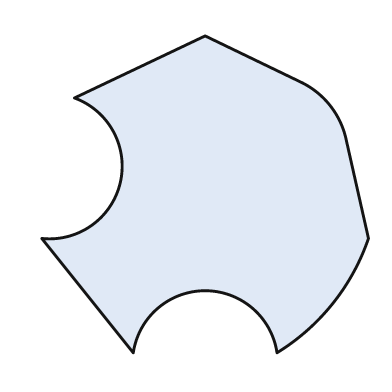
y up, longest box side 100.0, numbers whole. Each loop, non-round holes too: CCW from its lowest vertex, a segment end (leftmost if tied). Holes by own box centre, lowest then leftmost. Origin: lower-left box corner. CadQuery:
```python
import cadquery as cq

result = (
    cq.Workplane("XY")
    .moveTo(28.0, 0.0)
    .threePointArc((50.0, 19.0), (72.0, 0.0))
    .threePointArc((89.0, 15.0), (100.0, 35.0))
    .lineTo(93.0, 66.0)
    .threePointArc((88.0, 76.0), (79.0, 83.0))
    .lineTo(50.0, 97.0)
    .lineTo(10.0, 78.0)
    .threePointArc((24.0, 52.0), (0.0, 35.0))
    .close()
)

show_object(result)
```